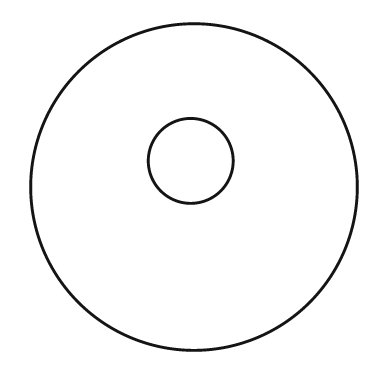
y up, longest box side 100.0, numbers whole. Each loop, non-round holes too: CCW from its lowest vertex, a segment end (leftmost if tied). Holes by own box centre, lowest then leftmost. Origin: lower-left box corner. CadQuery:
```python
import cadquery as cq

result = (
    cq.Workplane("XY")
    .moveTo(50.0, 50.0)
    .circle(50.0)
    .moveTo(49.0, 58.0)
    .circle(13.0)
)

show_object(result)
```